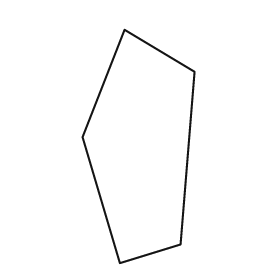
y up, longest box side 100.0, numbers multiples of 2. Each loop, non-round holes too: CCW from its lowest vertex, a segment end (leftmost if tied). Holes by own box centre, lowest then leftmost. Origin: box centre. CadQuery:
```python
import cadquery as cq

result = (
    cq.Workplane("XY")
    .moveTo(-8.0, -50.0)
    .lineTo(18.0, -42.0)
    .lineTo(24.0, 32.0)
    .lineTo(-6.0, 50.0)
    .lineTo(-24.0, 4.0)
    .close()
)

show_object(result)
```